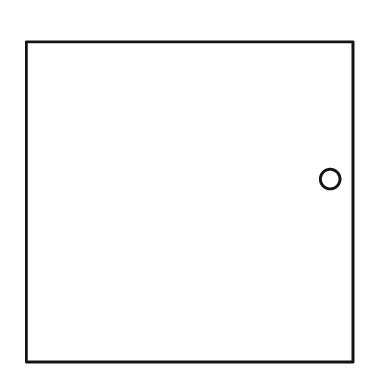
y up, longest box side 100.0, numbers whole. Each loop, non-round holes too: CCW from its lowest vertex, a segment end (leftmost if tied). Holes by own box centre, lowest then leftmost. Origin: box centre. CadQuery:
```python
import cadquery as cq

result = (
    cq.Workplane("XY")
    .moveTo(-50.0, -49.0)
    .lineTo(50.0, -49.0)
    .lineTo(50.0, 49.0)
    .lineTo(-50.0, 49.0)
    .close()
    .moveTo(43.0, 7.0)
    .circle(3.0)
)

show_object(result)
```